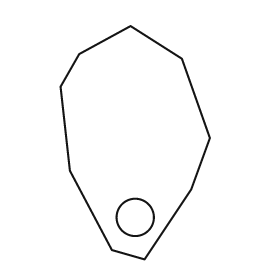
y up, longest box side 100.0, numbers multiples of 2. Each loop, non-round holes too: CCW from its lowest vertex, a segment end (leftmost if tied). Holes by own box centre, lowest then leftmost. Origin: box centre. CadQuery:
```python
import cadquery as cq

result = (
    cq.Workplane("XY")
    .moveTo(4.0, -50.0)
    .lineTo(24.0, -20.0)
    .lineTo(32.0, 2.0)
    .lineTo(20.0, 36.0)
    .lineTo(-2.0, 50.0)
    .lineTo(-24.0, 38.0)
    .lineTo(-32.0, 24.0)
    .lineTo(-28.0, -12.0)
    .lineTo(-10.0, -46.0)
    .close()
    .moveTo(0.0, -32.0)
    .circle(8.0)
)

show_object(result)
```